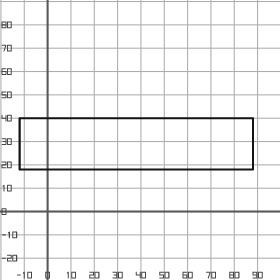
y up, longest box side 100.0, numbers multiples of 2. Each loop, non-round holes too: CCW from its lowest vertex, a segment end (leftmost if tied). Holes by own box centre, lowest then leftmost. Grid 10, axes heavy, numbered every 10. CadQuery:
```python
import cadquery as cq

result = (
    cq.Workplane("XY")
    .moveTo(-12.0, 18.0)
    .lineTo(88.0, 18.0)
    .lineTo(88.0, 40.0)
    .lineTo(-12.0, 40.0)
    .close()
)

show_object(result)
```